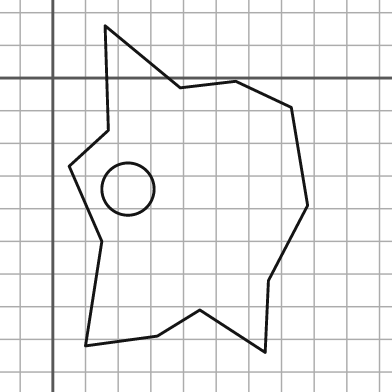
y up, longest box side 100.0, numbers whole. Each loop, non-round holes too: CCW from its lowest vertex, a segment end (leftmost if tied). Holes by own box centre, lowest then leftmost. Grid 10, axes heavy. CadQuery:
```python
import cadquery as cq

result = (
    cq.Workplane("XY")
    .moveTo(65.0, -84.0)
    .lineTo(66.0, -62.0)
    .lineTo(78.0, -39.0)
    .lineTo(73.0, -9.0)
    .lineTo(56.0, -1.0)
    .lineTo(39.0, -3.0)
    .lineTo(16.0, 16.0)
    .lineTo(17.0, -16.0)
    .lineTo(5.0, -27.0)
    .lineTo(15.0, -50.0)
    .lineTo(10.0, -82.0)
    .lineTo(32.0, -79.0)
    .lineTo(45.0, -71.0)
    .close()
    .moveTo(23.0, -34.0)
    .circle(8.0)
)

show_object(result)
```